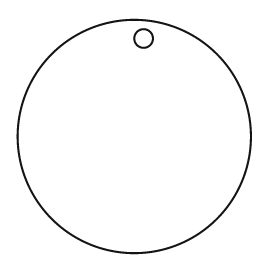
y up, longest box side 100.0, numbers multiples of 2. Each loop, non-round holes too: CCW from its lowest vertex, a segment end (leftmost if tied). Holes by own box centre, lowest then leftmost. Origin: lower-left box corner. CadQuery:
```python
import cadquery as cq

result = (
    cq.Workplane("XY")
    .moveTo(50.0, 50.0)
    .circle(50.0)
    .moveTo(54.0, 92.0)
    .circle(4.0)
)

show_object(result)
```